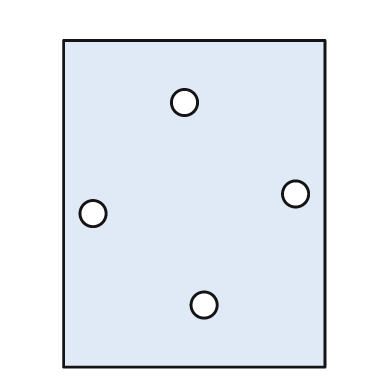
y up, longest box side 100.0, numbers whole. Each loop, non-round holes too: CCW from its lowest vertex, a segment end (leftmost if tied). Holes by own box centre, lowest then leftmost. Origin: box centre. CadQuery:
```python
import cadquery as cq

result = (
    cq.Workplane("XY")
    .moveTo(-40.0, -50.0)
    .lineTo(40.0, -50.0)
    .lineTo(40.0, 50.0)
    .lineTo(-40.0, 50.0)
    .close()
    .moveTo(3.0, -31.0)
    .circle(4.0)
    .moveTo(-31.0, -3.0)
    .circle(4.0)
    .moveTo(31.0, 3.0)
    .circle(4.0)
    .moveTo(-3.0, 31.0)
    .circle(4.0)
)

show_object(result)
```